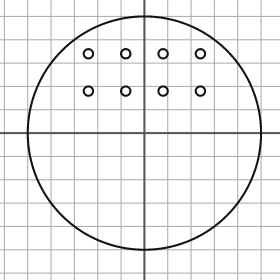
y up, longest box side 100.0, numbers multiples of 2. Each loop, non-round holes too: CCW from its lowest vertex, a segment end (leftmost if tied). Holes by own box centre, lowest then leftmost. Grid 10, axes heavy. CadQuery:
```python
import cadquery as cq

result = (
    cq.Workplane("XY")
    .moveTo(0.0, 0.0)
    .circle(50.0)
    .moveTo(-24.0, 18.0)
    .circle(2.0)
    .moveTo(-8.0, 18.0)
    .circle(2.0)
    .moveTo(8.0, 18.0)
    .circle(2.0)
    .moveTo(24.0, 18.0)
    .circle(2.0)
    .moveTo(-24.0, 34.0)
    .circle(2.0)
    .moveTo(-8.0, 34.0)
    .circle(2.0)
    .moveTo(8.0, 34.0)
    .circle(2.0)
    .moveTo(24.0, 34.0)
    .circle(2.0)
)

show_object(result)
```